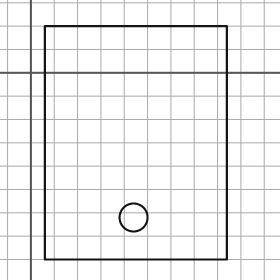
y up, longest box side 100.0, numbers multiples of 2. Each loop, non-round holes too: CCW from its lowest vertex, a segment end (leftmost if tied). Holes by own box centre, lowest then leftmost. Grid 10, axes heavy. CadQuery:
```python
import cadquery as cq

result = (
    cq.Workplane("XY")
    .moveTo(6.0, -80.0)
    .lineTo(84.0, -80.0)
    .lineTo(84.0, 20.0)
    .lineTo(6.0, 20.0)
    .close()
    .moveTo(44.0, -62.0)
    .circle(6.0)
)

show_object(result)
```